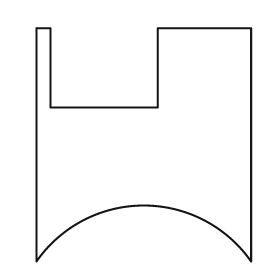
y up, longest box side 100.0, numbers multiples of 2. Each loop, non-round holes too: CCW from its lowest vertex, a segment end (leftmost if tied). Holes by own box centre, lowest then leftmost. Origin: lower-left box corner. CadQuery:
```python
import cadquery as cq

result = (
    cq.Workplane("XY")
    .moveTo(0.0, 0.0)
    .threePointArc((46.0, 24.0), (92.0, 0.0))
    .lineTo(92.0, 100.0)
    .lineTo(52.0, 100.0)
    .lineTo(52.0, 66.0)
    .lineTo(6.0, 66.0)
    .lineTo(6.0, 100.0)
    .lineTo(0.0, 100.0)
    .close()
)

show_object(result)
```